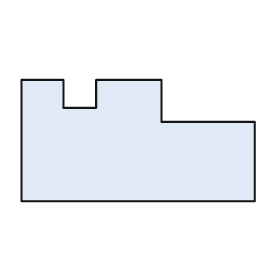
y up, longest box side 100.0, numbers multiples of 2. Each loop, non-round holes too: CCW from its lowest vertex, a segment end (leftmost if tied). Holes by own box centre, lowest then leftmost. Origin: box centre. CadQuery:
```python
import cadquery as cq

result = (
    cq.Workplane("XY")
    .moveTo(-50.0, -26.0)
    .lineTo(50.0, -26.0)
    .lineTo(50.0, 8.0)
    .lineTo(10.0, 8.0)
    .lineTo(10.0, 26.0)
    .lineTo(-18.0, 26.0)
    .lineTo(-18.0, 14.0)
    .lineTo(-32.0, 14.0)
    .lineTo(-32.0, 26.0)
    .lineTo(-50.0, 26.0)
    .close()
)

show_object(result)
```